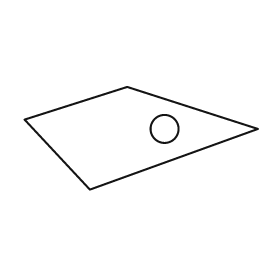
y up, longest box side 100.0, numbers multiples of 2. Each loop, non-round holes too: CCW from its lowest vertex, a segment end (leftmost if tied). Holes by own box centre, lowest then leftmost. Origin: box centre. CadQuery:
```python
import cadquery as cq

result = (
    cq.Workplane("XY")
    .moveTo(-22.0, -22.0)
    .lineTo(50.0, 4.0)
    .lineTo(-6.0, 22.0)
    .lineTo(-50.0, 8.0)
    .close()
    .moveTo(10.0, 4.0)
    .circle(6.0)
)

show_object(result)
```